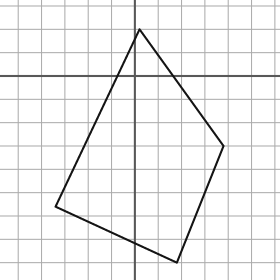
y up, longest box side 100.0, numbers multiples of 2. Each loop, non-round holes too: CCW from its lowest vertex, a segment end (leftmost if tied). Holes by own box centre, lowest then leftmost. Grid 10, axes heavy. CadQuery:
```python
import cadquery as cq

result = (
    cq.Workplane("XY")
    .moveTo(18.0, -80.0)
    .lineTo(38.0, -30.0)
    .lineTo(2.0, 20.0)
    .lineTo(-34.0, -56.0)
    .close()
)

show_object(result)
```